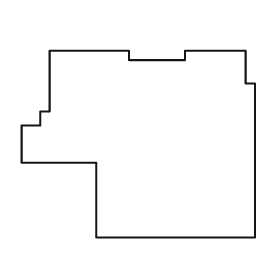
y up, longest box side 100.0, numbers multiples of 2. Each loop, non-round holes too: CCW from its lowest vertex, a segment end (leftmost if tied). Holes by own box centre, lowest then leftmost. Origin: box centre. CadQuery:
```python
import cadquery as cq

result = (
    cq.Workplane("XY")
    .moveTo(-18.0, -40.0)
    .lineTo(50.0, -40.0)
    .lineTo(50.0, 26.0)
    .lineTo(46.0, 26.0)
    .lineTo(46.0, 40.0)
    .lineTo(20.0, 40.0)
    .lineTo(20.0, 36.0)
    .lineTo(-4.0, 36.0)
    .lineTo(-4.0, 40.0)
    .lineTo(-38.0, 40.0)
    .lineTo(-38.0, 14.0)
    .lineTo(-42.0, 14.0)
    .lineTo(-42.0, 8.0)
    .lineTo(-50.0, 8.0)
    .lineTo(-50.0, -8.0)
    .lineTo(-18.0, -8.0)
    .close()
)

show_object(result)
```